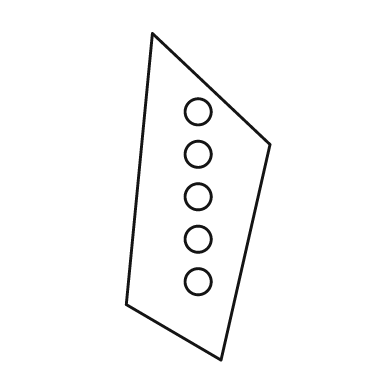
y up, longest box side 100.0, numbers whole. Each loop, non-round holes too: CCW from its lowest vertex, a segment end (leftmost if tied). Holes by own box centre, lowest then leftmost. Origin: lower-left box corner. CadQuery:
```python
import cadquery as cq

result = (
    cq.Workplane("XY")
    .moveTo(29.0, 0.0)
    .lineTo(44.0, 66.0)
    .lineTo(8.0, 100.0)
    .lineTo(0.0, 17.0)
    .close()
    .moveTo(22.0, 24.0)
    .circle(4.0)
    .moveTo(22.0, 37.0)
    .circle(4.0)
    .moveTo(22.0, 50.0)
    .circle(4.0)
    .moveTo(22.0, 63.0)
    .circle(4.0)
    .moveTo(22.0, 76.0)
    .circle(4.0)
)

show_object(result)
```